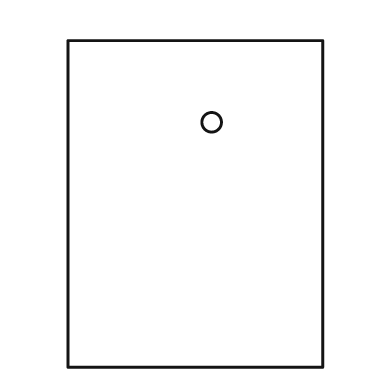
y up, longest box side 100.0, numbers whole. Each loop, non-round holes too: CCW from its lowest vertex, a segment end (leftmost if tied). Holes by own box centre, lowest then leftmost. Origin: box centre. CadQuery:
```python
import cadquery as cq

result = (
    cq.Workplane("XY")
    .moveTo(-39.0, -50.0)
    .lineTo(39.0, -50.0)
    .lineTo(39.0, 50.0)
    .lineTo(-39.0, 50.0)
    .close()
    .moveTo(5.0, 25.0)
    .circle(3.0)
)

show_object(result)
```